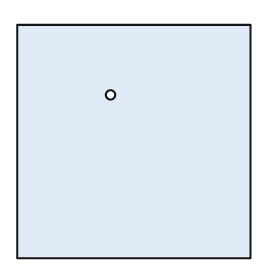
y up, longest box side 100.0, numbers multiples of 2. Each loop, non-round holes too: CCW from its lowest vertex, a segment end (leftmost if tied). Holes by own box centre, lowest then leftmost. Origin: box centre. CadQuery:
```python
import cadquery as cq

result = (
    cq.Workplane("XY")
    .moveTo(-50.0, -50.0)
    .lineTo(50.0, -50.0)
    .lineTo(50.0, 50.0)
    .lineTo(-50.0, 50.0)
    .close()
    .moveTo(-10.0, 20.0)
    .circle(2.0)
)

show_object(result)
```